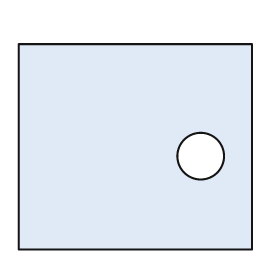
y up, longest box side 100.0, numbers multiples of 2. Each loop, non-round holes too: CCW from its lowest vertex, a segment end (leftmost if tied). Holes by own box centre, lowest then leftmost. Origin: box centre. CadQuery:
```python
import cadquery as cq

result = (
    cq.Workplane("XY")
    .moveTo(-50.0, -44.0)
    .lineTo(50.0, -44.0)
    .lineTo(50.0, 44.0)
    .lineTo(-50.0, 44.0)
    .close()
    .moveTo(28.0, -4.0)
    .circle(10.0)
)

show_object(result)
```